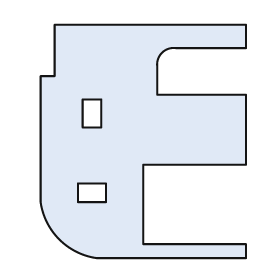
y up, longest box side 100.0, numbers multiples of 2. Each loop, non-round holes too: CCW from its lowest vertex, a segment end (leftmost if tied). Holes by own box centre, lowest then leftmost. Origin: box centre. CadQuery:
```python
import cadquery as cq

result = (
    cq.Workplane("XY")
    .moveTo(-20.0, -50.0)
    .lineTo(44.0, -50.0)
    .lineTo(44.0, -44.0)
    .lineTo(0.0, -44.0)
    .lineTo(0.0, -10.0)
    .lineTo(44.0, -10.0)
    .lineTo(44.0, 20.0)
    .lineTo(6.0, 20.0)
    .lineTo(6.0, 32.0)
    .threePointArc((8.0, 38.0), (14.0, 40.0))
    .lineTo(44.0, 40.0)
    .lineTo(44.0, 50.0)
    .lineTo(-38.0, 50.0)
    .lineTo(-38.0, 28.0)
    .lineTo(-44.0, 28.0)
    .lineTo(-44.0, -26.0)
    .threePointArc((-36.0, -42.0), (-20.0, -50.0))
    .close()
    .moveTo(-28.0, -26.0)
    .lineTo(-16.0, -26.0)
    .lineTo(-16.0, -18.0)
    .lineTo(-28.0, -18.0)
    .close()
    .moveTo(-26.0, 6.0)
    .lineTo(-18.0, 6.0)
    .lineTo(-18.0, 18.0)
    .lineTo(-26.0, 18.0)
    .close()
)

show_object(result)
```